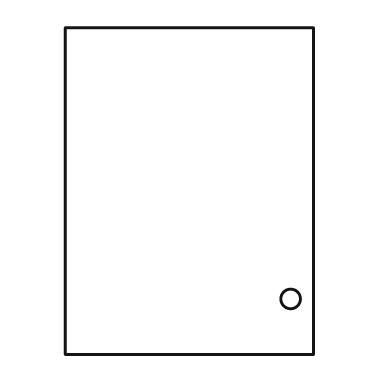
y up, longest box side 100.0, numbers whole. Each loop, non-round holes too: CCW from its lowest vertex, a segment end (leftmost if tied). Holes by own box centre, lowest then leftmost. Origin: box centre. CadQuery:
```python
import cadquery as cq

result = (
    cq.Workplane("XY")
    .moveTo(-38.0, -50.0)
    .lineTo(38.0, -50.0)
    .lineTo(38.0, 50.0)
    .lineTo(-38.0, 50.0)
    .close()
    .moveTo(31.0, -33.0)
    .circle(3.0)
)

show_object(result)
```